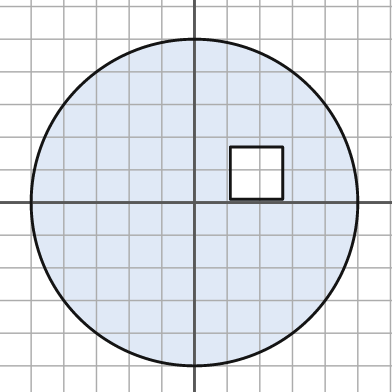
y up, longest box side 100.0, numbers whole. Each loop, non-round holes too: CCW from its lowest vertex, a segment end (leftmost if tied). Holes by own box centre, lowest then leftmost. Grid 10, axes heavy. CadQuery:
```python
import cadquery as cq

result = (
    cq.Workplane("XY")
    .moveTo(0.0, 0.0)
    .circle(50.0)
    .moveTo(11.0, 1.0)
    .lineTo(27.0, 1.0)
    .lineTo(27.0, 17.0)
    .lineTo(11.0, 17.0)
    .close()
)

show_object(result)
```